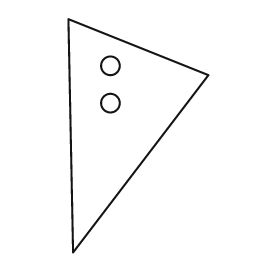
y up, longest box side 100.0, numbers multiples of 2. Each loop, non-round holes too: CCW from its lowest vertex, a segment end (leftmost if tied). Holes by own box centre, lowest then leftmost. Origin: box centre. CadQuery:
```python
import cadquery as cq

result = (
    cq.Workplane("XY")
    .moveTo(-28.0, -50.0)
    .lineTo(30.0, 26.0)
    .lineTo(-30.0, 50.0)
    .close()
    .moveTo(-12.0, 14.0)
    .circle(4.0)
    .moveTo(-12.0, 30.0)
    .circle(4.0)
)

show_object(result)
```